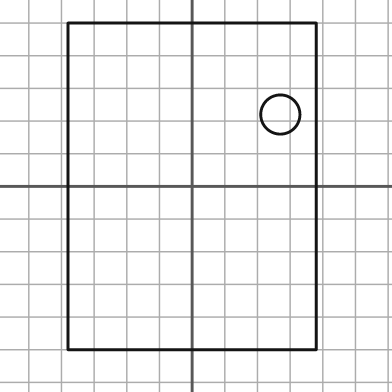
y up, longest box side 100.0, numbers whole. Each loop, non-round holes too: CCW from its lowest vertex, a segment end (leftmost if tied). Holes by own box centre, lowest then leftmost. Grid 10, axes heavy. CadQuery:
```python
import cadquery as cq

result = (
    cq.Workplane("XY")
    .moveTo(-38.0, -50.0)
    .lineTo(38.0, -50.0)
    .lineTo(38.0, 50.0)
    .lineTo(-38.0, 50.0)
    .close()
    .moveTo(27.0, 22.0)
    .circle(6.0)
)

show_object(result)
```